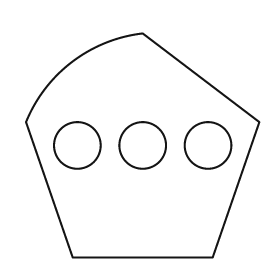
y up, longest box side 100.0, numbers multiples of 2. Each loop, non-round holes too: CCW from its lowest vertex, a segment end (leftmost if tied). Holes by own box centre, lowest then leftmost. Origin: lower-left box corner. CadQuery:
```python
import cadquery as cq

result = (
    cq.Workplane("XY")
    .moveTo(20.0, 0.0)
    .lineTo(80.0, 0.0)
    .lineTo(100.0, 58.0)
    .lineTo(50.0, 96.0)
    .threePointArc((20.0, 84.0), (0.0, 58.0))
    .close()
    .moveTo(22.0, 48.0)
    .circle(10.0)
    .moveTo(50.0, 48.0)
    .circle(10.0)
    .moveTo(78.0, 48.0)
    .circle(10.0)
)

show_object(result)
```